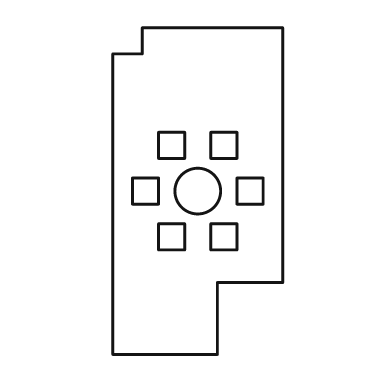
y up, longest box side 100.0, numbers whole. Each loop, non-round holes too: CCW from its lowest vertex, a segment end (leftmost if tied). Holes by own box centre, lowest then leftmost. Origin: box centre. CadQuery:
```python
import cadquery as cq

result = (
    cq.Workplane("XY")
    .moveTo(-26.0, -50.0)
    .lineTo(6.0, -50.0)
    .lineTo(6.0, -28.0)
    .lineTo(26.0, -28.0)
    .lineTo(26.0, 50.0)
    .lineTo(-17.0, 50.0)
    .lineTo(-17.0, 42.0)
    .lineTo(-26.0, 42.0)
    .close()
    .moveTo(-12.0, -18.0)
    .lineTo(-4.0, -18.0)
    .lineTo(-4.0, -10.0)
    .lineTo(-12.0, -10.0)
    .close()
    .moveTo(4.0, -18.0)
    .lineTo(12.0, -18.0)
    .lineTo(12.0, -10.0)
    .lineTo(4.0, -10.0)
    .close()
    .moveTo(-20.0, -4.0)
    .lineTo(-12.0, -4.0)
    .lineTo(-12.0, 4.0)
    .lineTo(-20.0, 4.0)
    .close()
    .moveTo(0.0, 0.0)
    .circle(7.0)
    .moveTo(12.0, -4.0)
    .lineTo(20.0, -4.0)
    .lineTo(20.0, 4.0)
    .lineTo(12.0, 4.0)
    .close()
    .moveTo(-12.0, 10.0)
    .lineTo(-4.0, 10.0)
    .lineTo(-4.0, 18.0)
    .lineTo(-12.0, 18.0)
    .close()
    .moveTo(4.0, 10.0)
    .lineTo(12.0, 10.0)
    .lineTo(12.0, 18.0)
    .lineTo(4.0, 18.0)
    .close()
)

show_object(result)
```